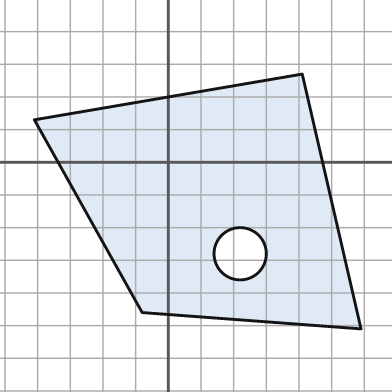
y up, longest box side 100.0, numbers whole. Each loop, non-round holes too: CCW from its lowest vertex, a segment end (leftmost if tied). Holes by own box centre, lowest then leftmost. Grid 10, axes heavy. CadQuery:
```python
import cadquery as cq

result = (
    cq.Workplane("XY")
    .moveTo(59.0, -51.0)
    .lineTo(41.0, 27.0)
    .lineTo(-41.0, 13.0)
    .lineTo(-8.0, -46.0)
    .close()
    .moveTo(22.0, -28.0)
    .circle(8.0)
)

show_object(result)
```